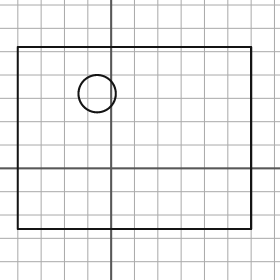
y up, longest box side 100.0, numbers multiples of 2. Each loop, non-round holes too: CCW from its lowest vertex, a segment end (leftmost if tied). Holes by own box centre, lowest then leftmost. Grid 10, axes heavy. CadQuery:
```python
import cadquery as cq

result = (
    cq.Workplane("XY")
    .moveTo(-40.0, -26.0)
    .lineTo(60.0, -26.0)
    .lineTo(60.0, 52.0)
    .lineTo(-40.0, 52.0)
    .close()
    .moveTo(-6.0, 32.0)
    .circle(8.0)
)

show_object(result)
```